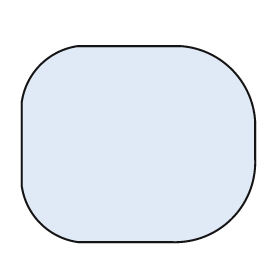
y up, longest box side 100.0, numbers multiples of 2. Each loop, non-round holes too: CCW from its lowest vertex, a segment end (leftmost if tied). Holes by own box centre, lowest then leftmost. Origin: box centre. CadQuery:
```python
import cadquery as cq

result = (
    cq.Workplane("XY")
    .moveTo(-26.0, -42.0)
    .lineTo(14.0, -42.0)
    .threePointArc((40.0, -32.0), (50.0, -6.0))
    .lineTo(50.0, 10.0)
    .threePointArc((40.0, 32.0), (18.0, 42.0))
    .lineTo(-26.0, 42.0)
    .threePointArc((-42.0, 34.0), (-50.0, 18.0))
    .lineTo(-50.0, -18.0)
    .threePointArc((-42.0, -34.0), (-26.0, -42.0))
    .close()
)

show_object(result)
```